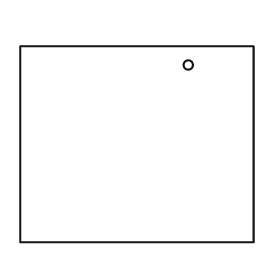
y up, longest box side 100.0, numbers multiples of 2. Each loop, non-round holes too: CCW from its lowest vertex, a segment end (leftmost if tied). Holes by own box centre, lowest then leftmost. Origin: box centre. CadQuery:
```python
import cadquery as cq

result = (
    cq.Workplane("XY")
    .moveTo(-50.0, -42.0)
    .lineTo(50.0, -42.0)
    .lineTo(50.0, 42.0)
    .lineTo(-50.0, 42.0)
    .close()
    .moveTo(22.0, 34.0)
    .circle(2.0)
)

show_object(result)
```